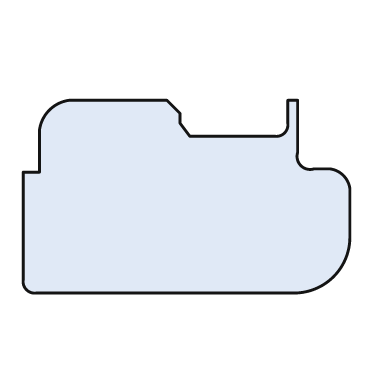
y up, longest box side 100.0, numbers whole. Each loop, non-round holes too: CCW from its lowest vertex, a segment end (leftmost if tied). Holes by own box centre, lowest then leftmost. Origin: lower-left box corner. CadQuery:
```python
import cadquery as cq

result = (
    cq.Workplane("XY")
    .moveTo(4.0, 0.0)
    .lineTo(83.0, 0.0)
    .threePointArc((95.0, 5.0), (100.0, 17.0))
    .lineTo(100.0, 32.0)
    .threePointArc((98.0, 36.0), (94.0, 38.0))
    .lineTo(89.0, 38.0)
    .threePointArc((85.0, 39.0), (84.0, 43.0))
    .lineTo(84.0, 59.0)
    .lineTo(81.0, 59.0)
    .lineTo(81.0, 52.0)
    .threePointArc((80.0, 49.0), (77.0, 48.0))
    .lineTo(51.0, 48.0)
    .lineTo(48.0, 52.0)
    .lineTo(48.0, 55.0)
    .lineTo(44.0, 59.0)
    .lineTo(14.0, 59.0)
    .threePointArc((8.0, 56.0), (5.0, 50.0))
    .lineTo(5.0, 37.0)
    .lineTo(0.0, 37.0)
    .lineTo(0.0, 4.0)
    .threePointArc((1.0, 1.0), (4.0, 0.0))
    .close()
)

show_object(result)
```